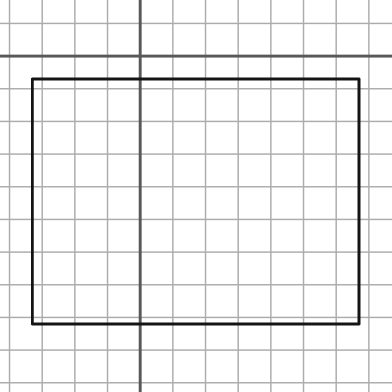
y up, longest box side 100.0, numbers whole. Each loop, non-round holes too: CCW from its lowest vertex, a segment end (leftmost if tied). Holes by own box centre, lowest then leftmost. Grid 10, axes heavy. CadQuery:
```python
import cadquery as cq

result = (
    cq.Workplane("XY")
    .moveTo(-33.0, -82.0)
    .lineTo(67.0, -82.0)
    .lineTo(67.0, -7.0)
    .lineTo(-33.0, -7.0)
    .close()
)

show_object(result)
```